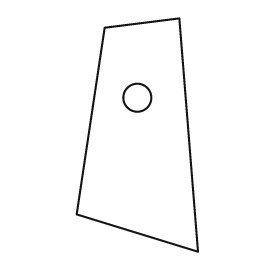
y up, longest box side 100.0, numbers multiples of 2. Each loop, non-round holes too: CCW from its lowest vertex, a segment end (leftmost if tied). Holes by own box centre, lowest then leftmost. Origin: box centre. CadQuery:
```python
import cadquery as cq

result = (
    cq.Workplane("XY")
    .moveTo(26.0, -50.0)
    .lineTo(18.0, 50.0)
    .lineTo(-14.0, 46.0)
    .lineTo(-26.0, -34.0)
    .close()
    .moveTo(0.0, 16.0)
    .circle(6.0)
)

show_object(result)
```